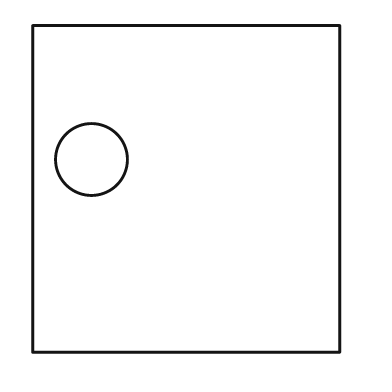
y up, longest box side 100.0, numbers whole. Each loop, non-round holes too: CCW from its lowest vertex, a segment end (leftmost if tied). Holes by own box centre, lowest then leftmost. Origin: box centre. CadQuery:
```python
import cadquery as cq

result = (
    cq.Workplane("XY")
    .moveTo(-47.0, -50.0)
    .lineTo(47.0, -50.0)
    .lineTo(47.0, 50.0)
    .lineTo(-47.0, 50.0)
    .close()
    .moveTo(-29.0, 9.0)
    .circle(11.0)
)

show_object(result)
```